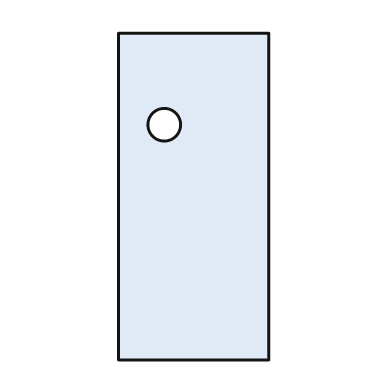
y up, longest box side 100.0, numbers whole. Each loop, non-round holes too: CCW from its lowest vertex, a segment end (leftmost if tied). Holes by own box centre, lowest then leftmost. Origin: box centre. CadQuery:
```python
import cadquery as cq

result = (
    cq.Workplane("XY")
    .moveTo(-23.0, -50.0)
    .lineTo(23.0, -50.0)
    .lineTo(23.0, 50.0)
    .lineTo(-23.0, 50.0)
    .close()
    .moveTo(-9.0, 22.0)
    .circle(5.0)
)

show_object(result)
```